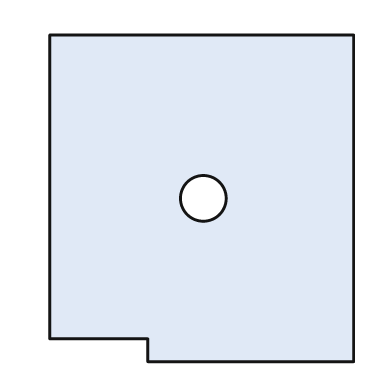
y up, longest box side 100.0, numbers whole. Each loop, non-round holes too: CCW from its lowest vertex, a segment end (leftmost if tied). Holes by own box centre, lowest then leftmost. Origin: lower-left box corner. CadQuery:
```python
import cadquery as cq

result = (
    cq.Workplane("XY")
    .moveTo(30.0, 0.0)
    .lineTo(93.0, 0.0)
    .lineTo(93.0, 100.0)
    .lineTo(0.0, 100.0)
    .lineTo(0.0, 7.0)
    .lineTo(30.0, 7.0)
    .close()
    .moveTo(47.0, 50.0)
    .circle(7.0)
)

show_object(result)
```